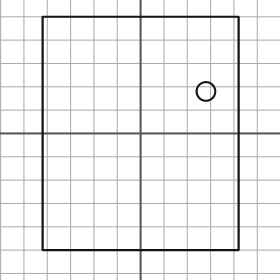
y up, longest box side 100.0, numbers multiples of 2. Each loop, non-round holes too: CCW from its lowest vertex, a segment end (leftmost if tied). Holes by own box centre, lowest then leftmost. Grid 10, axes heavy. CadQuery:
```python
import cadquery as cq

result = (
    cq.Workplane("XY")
    .moveTo(-42.0, -50.0)
    .lineTo(42.0, -50.0)
    .lineTo(42.0, 50.0)
    .lineTo(-42.0, 50.0)
    .close()
    .moveTo(28.0, 18.0)
    .circle(4.0)
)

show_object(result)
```